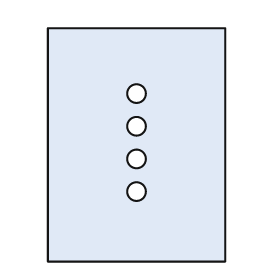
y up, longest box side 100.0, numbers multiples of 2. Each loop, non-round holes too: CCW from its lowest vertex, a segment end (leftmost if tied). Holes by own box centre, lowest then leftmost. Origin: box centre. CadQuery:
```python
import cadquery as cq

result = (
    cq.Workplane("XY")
    .moveTo(-38.0, -50.0)
    .lineTo(38.0, -50.0)
    .lineTo(38.0, 50.0)
    .lineTo(-38.0, 50.0)
    .close()
    .moveTo(0.0, -20.0)
    .circle(4.0)
    .moveTo(0.0, -6.0)
    .circle(4.0)
    .moveTo(0.0, 8.0)
    .circle(4.0)
    .moveTo(0.0, 22.0)
    .circle(4.0)
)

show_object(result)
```